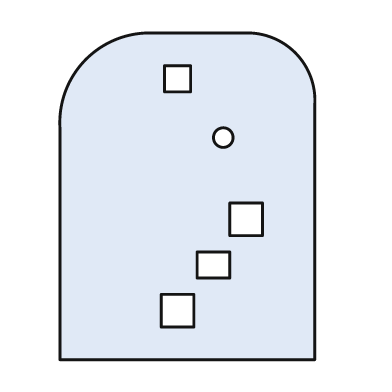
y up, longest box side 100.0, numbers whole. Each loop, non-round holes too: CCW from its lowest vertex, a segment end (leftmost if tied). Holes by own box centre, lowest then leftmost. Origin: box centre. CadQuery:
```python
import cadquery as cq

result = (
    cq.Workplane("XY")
    .moveTo(-39.0, -50.0)
    .lineTo(39.0, -50.0)
    .lineTo(39.0, 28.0)
    .threePointArc((33.0, 44.0), (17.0, 50.0))
    .lineTo(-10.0, 50.0)
    .threePointArc((-31.0, 42.0), (-39.0, 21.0))
    .close()
    .moveTo(-8.0, -40.0)
    .lineTo(2.0, -40.0)
    .lineTo(2.0, -30.0)
    .lineTo(-8.0, -30.0)
    .close()
    .moveTo(3.0, -25.0)
    .lineTo(13.0, -25.0)
    .lineTo(13.0, -17.0)
    .lineTo(3.0, -17.0)
    .close()
    .moveTo(13.0, -12.0)
    .lineTo(23.0, -12.0)
    .lineTo(23.0, -2.0)
    .lineTo(13.0, -2.0)
    .close()
    .moveTo(11.0, 18.0)
    .circle(3.0)
    .moveTo(-7.0, 32.0)
    .lineTo(1.0, 32.0)
    .lineTo(1.0, 40.0)
    .lineTo(-7.0, 40.0)
    .close()
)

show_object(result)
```